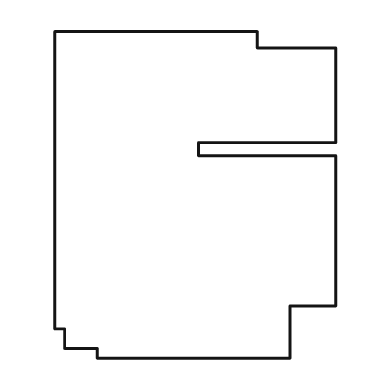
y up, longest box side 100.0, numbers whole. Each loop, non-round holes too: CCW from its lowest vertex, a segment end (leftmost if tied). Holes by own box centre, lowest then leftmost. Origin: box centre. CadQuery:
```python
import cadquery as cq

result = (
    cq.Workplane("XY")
    .moveTo(-30.0, -50.0)
    .lineTo(29.0, -50.0)
    .lineTo(29.0, -34.0)
    .lineTo(43.0, -34.0)
    .lineTo(43.0, 12.0)
    .lineTo(1.0, 12.0)
    .lineTo(1.0, 16.0)
    .lineTo(43.0, 16.0)
    .lineTo(43.0, 45.0)
    .lineTo(19.0, 45.0)
    .lineTo(19.0, 50.0)
    .lineTo(-43.0, 50.0)
    .lineTo(-43.0, -41.0)
    .lineTo(-40.0, -41.0)
    .lineTo(-40.0, -47.0)
    .lineTo(-30.0, -47.0)
    .close()
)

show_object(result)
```